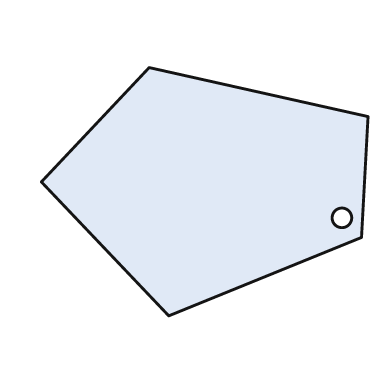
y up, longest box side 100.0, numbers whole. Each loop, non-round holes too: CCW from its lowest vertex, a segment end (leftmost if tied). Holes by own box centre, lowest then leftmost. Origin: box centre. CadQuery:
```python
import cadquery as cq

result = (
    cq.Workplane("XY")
    .moveTo(-11.0, -38.0)
    .lineTo(48.0, -14.0)
    .lineTo(50.0, 23.0)
    .lineTo(-17.0, 38.0)
    .lineTo(-50.0, 3.0)
    .close()
    .moveTo(42.0, -8.0)
    .circle(3.0)
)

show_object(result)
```